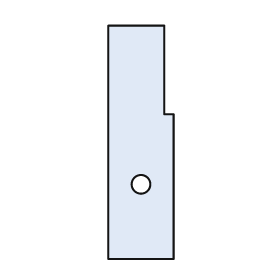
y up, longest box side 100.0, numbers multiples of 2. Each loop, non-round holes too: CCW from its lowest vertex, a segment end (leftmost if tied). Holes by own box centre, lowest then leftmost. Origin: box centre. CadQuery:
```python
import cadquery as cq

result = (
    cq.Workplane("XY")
    .moveTo(-14.0, -50.0)
    .lineTo(14.0, -50.0)
    .lineTo(14.0, 12.0)
    .lineTo(10.0, 12.0)
    .lineTo(10.0, 50.0)
    .lineTo(-14.0, 50.0)
    .close()
    .moveTo(0.0, -18.0)
    .circle(4.0)
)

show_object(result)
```